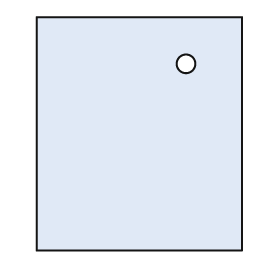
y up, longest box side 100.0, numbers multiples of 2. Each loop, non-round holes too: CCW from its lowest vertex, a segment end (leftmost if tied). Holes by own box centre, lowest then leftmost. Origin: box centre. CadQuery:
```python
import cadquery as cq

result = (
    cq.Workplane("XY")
    .moveTo(-44.0, -50.0)
    .lineTo(44.0, -50.0)
    .lineTo(44.0, 50.0)
    .lineTo(-44.0, 50.0)
    .close()
    .moveTo(20.0, 30.0)
    .circle(4.0)
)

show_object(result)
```